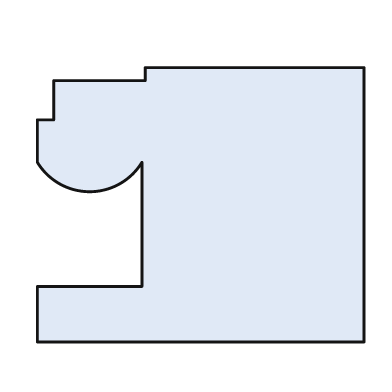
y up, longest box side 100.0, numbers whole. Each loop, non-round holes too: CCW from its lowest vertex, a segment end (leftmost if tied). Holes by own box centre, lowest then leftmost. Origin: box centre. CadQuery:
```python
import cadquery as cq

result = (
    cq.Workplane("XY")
    .moveTo(-50.0, -42.0)
    .lineTo(50.0, -42.0)
    .lineTo(50.0, 42.0)
    .lineTo(-17.0, 42.0)
    .lineTo(-17.0, 38.0)
    .lineTo(-45.0, 38.0)
    .lineTo(-45.0, 26.0)
    .lineTo(-50.0, 26.0)
    .lineTo(-50.0, 13.0)
    .threePointArc((-34.0, 4.0), (-18.0, 13.0))
    .lineTo(-18.0, -25.0)
    .lineTo(-50.0, -25.0)
    .close()
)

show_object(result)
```